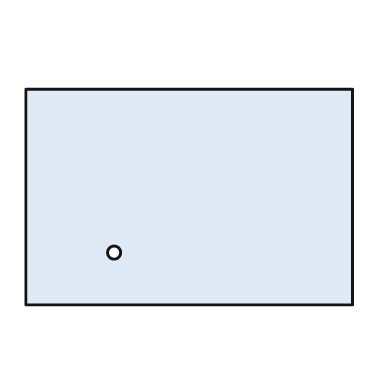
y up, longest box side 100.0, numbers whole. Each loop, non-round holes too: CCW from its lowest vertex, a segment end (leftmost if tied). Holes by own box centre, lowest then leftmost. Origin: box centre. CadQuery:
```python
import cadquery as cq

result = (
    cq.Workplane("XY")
    .moveTo(-50.0, -33.0)
    .lineTo(50.0, -33.0)
    .lineTo(50.0, 33.0)
    .lineTo(-50.0, 33.0)
    .close()
    .moveTo(-23.0, -17.0)
    .circle(2.0)
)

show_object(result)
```